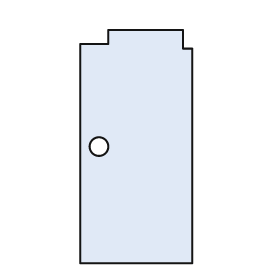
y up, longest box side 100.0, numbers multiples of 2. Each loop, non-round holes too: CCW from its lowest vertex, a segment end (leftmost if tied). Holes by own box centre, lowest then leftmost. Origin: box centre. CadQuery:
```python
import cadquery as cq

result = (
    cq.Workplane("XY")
    .moveTo(-24.0, -50.0)
    .lineTo(24.0, -50.0)
    .lineTo(24.0, 42.0)
    .lineTo(20.0, 42.0)
    .lineTo(20.0, 50.0)
    .lineTo(-12.0, 50.0)
    .lineTo(-12.0, 44.0)
    .lineTo(-24.0, 44.0)
    .close()
    .moveTo(-16.0, 0.0)
    .circle(4.0)
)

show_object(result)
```